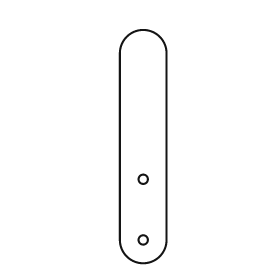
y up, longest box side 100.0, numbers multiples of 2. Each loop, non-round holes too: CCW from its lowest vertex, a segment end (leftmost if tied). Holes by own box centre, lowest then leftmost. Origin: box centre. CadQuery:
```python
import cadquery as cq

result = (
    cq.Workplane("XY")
    .moveTo(-10.0, -40.0)
    .threePointArc((0.0, -50.0), (10.0, -40.0))
    .lineTo(10.0, 40.0)
    .threePointArc((0.0, 50.0), (-10.0, 40.0))
    .close()
    .moveTo(0.0, -40.0)
    .circle(2.0)
    .moveTo(0.0, -14.0)
    .circle(2.0)
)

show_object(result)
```